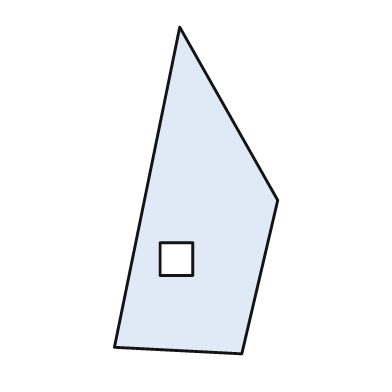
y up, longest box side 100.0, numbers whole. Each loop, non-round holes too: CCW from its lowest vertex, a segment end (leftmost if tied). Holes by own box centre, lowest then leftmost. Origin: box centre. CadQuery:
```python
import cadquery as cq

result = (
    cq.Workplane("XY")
    .moveTo(14.0, -50.0)
    .lineTo(25.0, -3.0)
    .lineTo(-5.0, 50.0)
    .lineTo(-25.0, -48.0)
    .close()
    .moveTo(-11.0, -26.0)
    .lineTo(-1.0, -26.0)
    .lineTo(-1.0, -16.0)
    .lineTo(-11.0, -16.0)
    .close()
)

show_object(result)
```